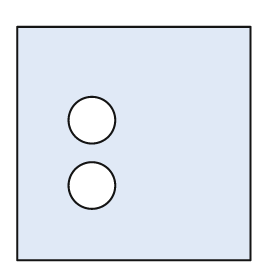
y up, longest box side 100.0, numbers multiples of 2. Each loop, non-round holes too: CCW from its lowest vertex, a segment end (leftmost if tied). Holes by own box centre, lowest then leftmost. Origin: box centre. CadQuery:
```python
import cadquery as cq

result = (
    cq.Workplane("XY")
    .moveTo(-50.0, -50.0)
    .lineTo(50.0, -50.0)
    .lineTo(50.0, 50.0)
    .lineTo(-50.0, 50.0)
    .close()
    .moveTo(-18.0, -18.0)
    .circle(10.0)
    .moveTo(-18.0, 10.0)
    .circle(10.0)
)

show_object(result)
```